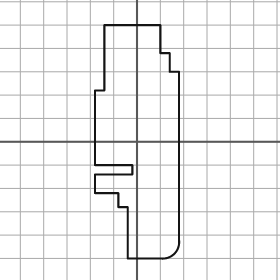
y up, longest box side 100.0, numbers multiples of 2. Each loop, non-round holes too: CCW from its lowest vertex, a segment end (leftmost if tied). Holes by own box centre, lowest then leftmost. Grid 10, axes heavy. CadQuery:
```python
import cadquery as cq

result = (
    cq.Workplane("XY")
    .moveTo(-4.0, -50.0)
    .lineTo(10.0, -50.0)
    .threePointArc((16.0, -48.0), (18.0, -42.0))
    .lineTo(18.0, 30.0)
    .lineTo(14.0, 30.0)
    .lineTo(14.0, 38.0)
    .lineTo(10.0, 38.0)
    .lineTo(10.0, 50.0)
    .lineTo(-14.0, 50.0)
    .lineTo(-14.0, 22.0)
    .lineTo(-18.0, 22.0)
    .lineTo(-18.0, -10.0)
    .lineTo(-2.0, -10.0)
    .lineTo(-2.0, -14.0)
    .lineTo(-18.0, -14.0)
    .lineTo(-18.0, -22.0)
    .lineTo(-8.0, -22.0)
    .lineTo(-8.0, -28.0)
    .lineTo(-4.0, -28.0)
    .close()
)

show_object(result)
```